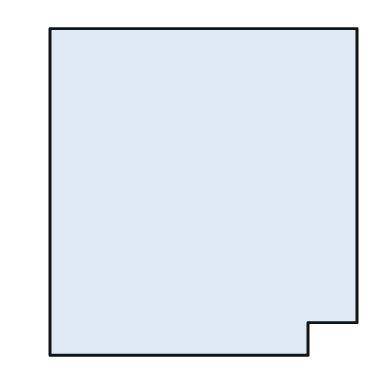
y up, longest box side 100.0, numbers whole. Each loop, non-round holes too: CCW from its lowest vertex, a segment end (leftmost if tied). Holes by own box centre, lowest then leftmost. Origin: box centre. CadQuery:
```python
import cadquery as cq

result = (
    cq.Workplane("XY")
    .moveTo(-47.0, -50.0)
    .lineTo(32.0, -50.0)
    .lineTo(32.0, -40.0)
    .lineTo(47.0, -40.0)
    .lineTo(47.0, 50.0)
    .lineTo(-47.0, 50.0)
    .close()
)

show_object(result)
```